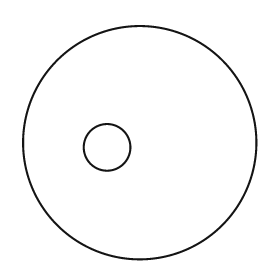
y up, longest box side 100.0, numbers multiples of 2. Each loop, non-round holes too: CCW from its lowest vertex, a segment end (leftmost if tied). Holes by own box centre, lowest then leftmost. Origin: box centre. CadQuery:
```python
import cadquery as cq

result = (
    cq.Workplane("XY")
    .moveTo(0.0, 0.0)
    .circle(50.0)
    .moveTo(-14.0, -2.0)
    .circle(10.0)
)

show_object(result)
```